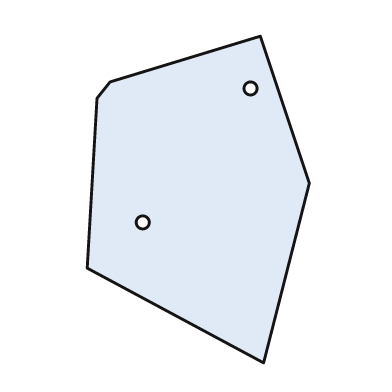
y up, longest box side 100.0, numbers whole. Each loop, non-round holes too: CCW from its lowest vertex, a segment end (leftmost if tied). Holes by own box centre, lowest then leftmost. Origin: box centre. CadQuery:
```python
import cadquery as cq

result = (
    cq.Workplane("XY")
    .moveTo(20.0, -50.0)
    .lineTo(34.0, 5.0)
    .lineTo(19.0, 50.0)
    .lineTo(-27.0, 36.0)
    .lineTo(-31.0, 31.0)
    .lineTo(-34.0, -21.0)
    .close()
    .moveTo(-17.0, -7.0)
    .circle(2.0)
    .moveTo(16.0, 34.0)
    .circle(2.0)
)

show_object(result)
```